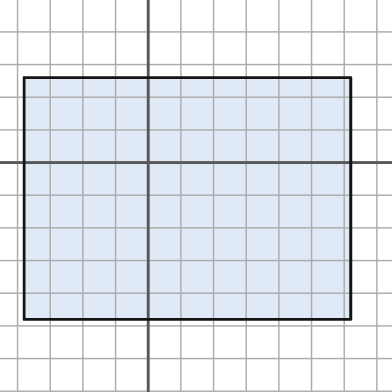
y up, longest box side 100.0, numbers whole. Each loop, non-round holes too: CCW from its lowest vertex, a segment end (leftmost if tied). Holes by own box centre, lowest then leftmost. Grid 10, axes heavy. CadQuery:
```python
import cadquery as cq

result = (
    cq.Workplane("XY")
    .moveTo(-38.0, -48.0)
    .lineTo(62.0, -48.0)
    .lineTo(62.0, 26.0)
    .lineTo(-38.0, 26.0)
    .close()
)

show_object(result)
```